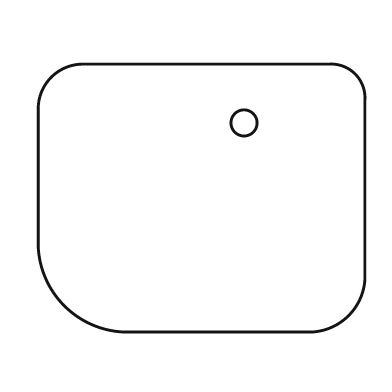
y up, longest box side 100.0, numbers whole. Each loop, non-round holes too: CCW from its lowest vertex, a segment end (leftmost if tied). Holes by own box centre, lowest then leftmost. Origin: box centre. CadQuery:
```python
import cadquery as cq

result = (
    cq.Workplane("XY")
    .moveTo(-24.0, -41.0)
    .lineTo(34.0, -41.0)
    .threePointArc((45.0, -36.0), (50.0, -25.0))
    .lineTo(50.0, 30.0)
    .threePointArc((47.0, 38.0), (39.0, 41.0))
    .lineTo(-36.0, 41.0)
    .threePointArc((-46.0, 37.0), (-50.0, 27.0))
    .lineTo(-50.0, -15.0)
    .threePointArc((-42.0, -33.0), (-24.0, -41.0))
    .close()
    .moveTo(13.0, 23.0)
    .circle(4.0)
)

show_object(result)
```